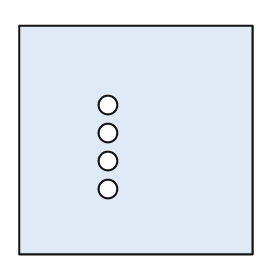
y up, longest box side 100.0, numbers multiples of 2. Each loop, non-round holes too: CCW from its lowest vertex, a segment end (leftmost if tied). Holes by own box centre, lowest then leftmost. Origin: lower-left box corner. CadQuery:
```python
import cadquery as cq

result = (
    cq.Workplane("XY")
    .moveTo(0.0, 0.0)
    .lineTo(100.0, 0.0)
    .lineTo(100.0, 98.0)
    .lineTo(0.0, 98.0)
    .close()
    .moveTo(38.0, 28.0)
    .circle(4.0)
    .moveTo(38.0, 40.0)
    .circle(4.0)
    .moveTo(38.0, 52.0)
    .circle(4.0)
    .moveTo(38.0, 64.0)
    .circle(4.0)
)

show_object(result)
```